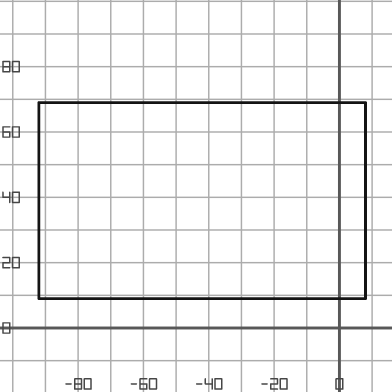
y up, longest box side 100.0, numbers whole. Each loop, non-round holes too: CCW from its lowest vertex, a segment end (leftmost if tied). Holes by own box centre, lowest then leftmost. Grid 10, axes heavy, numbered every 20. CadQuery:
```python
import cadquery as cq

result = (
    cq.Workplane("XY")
    .moveTo(-92.0, 9.0)
    .lineTo(8.0, 9.0)
    .lineTo(8.0, 69.0)
    .lineTo(-92.0, 69.0)
    .close()
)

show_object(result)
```